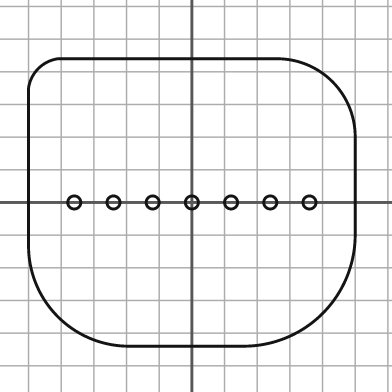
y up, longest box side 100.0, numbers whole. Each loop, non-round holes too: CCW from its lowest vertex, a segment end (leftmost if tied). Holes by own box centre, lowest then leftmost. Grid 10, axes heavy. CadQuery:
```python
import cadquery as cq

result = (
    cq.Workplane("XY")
    .moveTo(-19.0, -44.0)
    .lineTo(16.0, -44.0)
    .threePointArc((40.0, -34.0), (50.0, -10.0))
    .lineTo(50.0, 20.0)
    .threePointArc((43.0, 37.0), (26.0, 44.0))
    .lineTo(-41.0, 44.0)
    .threePointArc((-47.0, 41.0), (-50.0, 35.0))
    .lineTo(-50.0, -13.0)
    .threePointArc((-41.0, -35.0), (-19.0, -44.0))
    .close()
    .moveTo(-36.0, 0.0)
    .circle(2.0)
    .moveTo(-24.0, 0.0)
    .circle(2.0)
    .moveTo(-12.0, 0.0)
    .circle(2.0)
    .moveTo(0.0, 0.0)
    .circle(2.0)
    .moveTo(12.0, 0.0)
    .circle(2.0)
    .moveTo(24.0, 0.0)
    .circle(2.0)
    .moveTo(36.0, 0.0)
    .circle(2.0)
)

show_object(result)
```